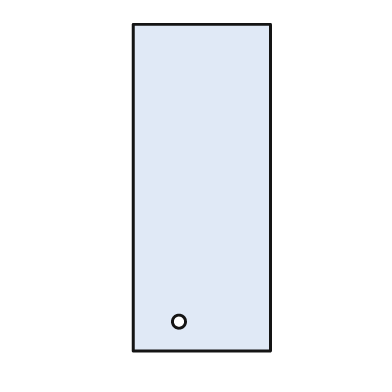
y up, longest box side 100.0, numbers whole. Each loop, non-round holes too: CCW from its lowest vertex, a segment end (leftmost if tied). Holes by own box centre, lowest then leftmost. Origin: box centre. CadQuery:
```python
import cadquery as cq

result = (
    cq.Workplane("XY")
    .moveTo(-21.0, -50.0)
    .lineTo(21.0, -50.0)
    .lineTo(21.0, 50.0)
    .lineTo(-21.0, 50.0)
    .close()
    .moveTo(-7.0, -41.0)
    .circle(2.0)
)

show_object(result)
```